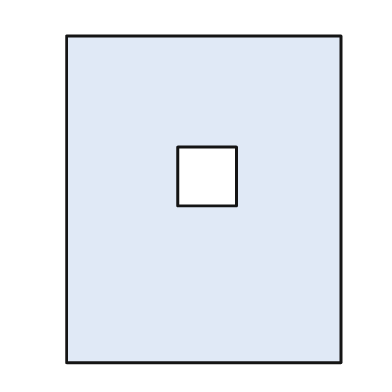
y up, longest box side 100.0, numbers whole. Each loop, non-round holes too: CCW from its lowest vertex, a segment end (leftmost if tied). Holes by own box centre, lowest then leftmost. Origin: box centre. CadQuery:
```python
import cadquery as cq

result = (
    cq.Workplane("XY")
    .moveTo(-42.0, -50.0)
    .lineTo(42.0, -50.0)
    .lineTo(42.0, 50.0)
    .lineTo(-42.0, 50.0)
    .close()
    .moveTo(-8.0, -2.0)
    .lineTo(10.0, -2.0)
    .lineTo(10.0, 16.0)
    .lineTo(-8.0, 16.0)
    .close()
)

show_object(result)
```